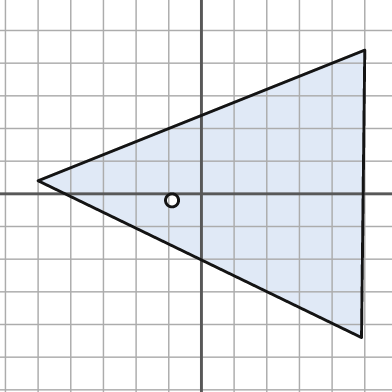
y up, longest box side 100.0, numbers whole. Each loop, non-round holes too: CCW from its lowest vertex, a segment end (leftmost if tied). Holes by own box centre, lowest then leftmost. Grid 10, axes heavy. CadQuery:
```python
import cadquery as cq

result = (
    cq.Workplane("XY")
    .moveTo(49.0, -44.0)
    .lineTo(50.0, 44.0)
    .lineTo(-50.0, 4.0)
    .close()
    .moveTo(-9.0, -2.0)
    .circle(2.0)
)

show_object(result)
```